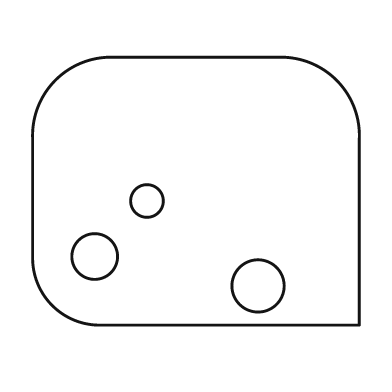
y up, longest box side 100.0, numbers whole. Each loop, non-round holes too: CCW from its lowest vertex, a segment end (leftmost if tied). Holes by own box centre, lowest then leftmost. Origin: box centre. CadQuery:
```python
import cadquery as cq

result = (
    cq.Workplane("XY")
    .moveTo(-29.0, -41.0)
    .lineTo(50.0, -41.0)
    .lineTo(50.0, 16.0)
    .threePointArc((43.0, 34.0), (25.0, 41.0))
    .lineTo(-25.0, 41.0)
    .threePointArc((-43.0, 34.0), (-50.0, 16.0))
    .lineTo(-50.0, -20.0)
    .threePointArc((-44.0, -35.0), (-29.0, -41.0))
    .close()
    .moveTo(19.0, -29.0)
    .circle(8.0)
    .moveTo(-31.0, -20.0)
    .circle(7.0)
    .moveTo(-15.0, -3.0)
    .circle(5.0)
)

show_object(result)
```